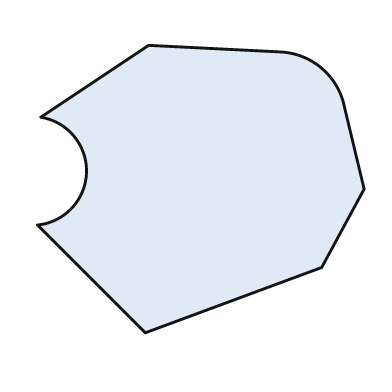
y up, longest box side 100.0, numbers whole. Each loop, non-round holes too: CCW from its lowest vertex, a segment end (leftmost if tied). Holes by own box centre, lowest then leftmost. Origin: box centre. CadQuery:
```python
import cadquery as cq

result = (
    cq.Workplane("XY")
    .moveTo(-17.0, -44.0)
    .lineTo(37.0, -24.0)
    .lineTo(50.0, 0.0)
    .lineTo(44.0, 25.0)
    .threePointArc((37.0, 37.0), (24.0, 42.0))
    .lineTo(-16.0, 44.0)
    .lineTo(-49.0, 22.0)
    .threePointArc((-35.0, 5.0), (-50.0, -11.0))
    .close()
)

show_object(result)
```